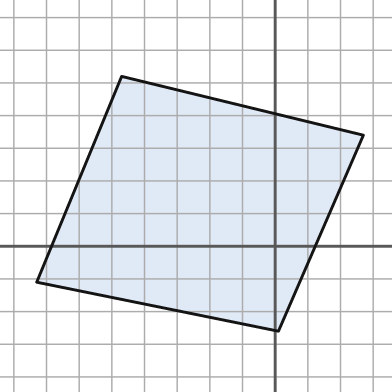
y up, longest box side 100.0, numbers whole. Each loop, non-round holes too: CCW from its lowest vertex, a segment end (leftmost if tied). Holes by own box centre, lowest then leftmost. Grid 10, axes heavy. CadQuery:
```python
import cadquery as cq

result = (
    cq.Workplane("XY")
    .moveTo(1.0, -26.0)
    .lineTo(27.0, 34.0)
    .lineTo(-47.0, 52.0)
    .lineTo(-73.0, -11.0)
    .close()
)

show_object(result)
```